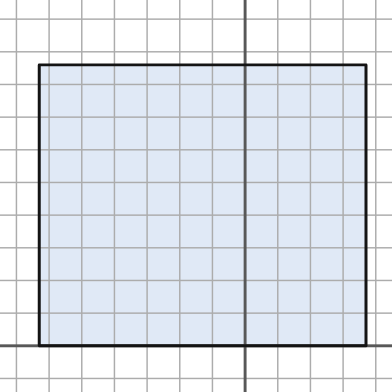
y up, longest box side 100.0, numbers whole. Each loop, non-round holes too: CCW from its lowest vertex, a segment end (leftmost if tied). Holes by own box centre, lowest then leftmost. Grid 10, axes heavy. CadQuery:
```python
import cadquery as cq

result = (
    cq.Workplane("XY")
    .moveTo(-63.0, 0.0)
    .lineTo(37.0, 0.0)
    .lineTo(37.0, 86.0)
    .lineTo(-63.0, 86.0)
    .close()
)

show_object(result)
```